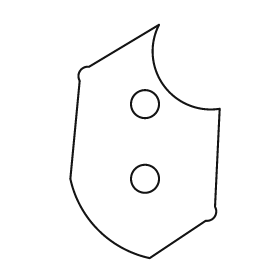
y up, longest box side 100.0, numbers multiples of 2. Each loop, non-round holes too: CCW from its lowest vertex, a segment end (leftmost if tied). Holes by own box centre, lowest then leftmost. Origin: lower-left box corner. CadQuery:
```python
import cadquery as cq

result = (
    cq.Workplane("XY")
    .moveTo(34.0, 0.0)
    .lineTo(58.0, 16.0)
    .threePointArc((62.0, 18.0), (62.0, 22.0))
    .lineTo(64.0, 64.0)
    .threePointArc((40.0, 74.0), (38.0, 100.0))
    .lineTo(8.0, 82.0)
    .threePointArc((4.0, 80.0), (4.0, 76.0))
    .lineTo(0.0, 34.0)
    .threePointArc((12.0, 12.0), (34.0, 0.0))
    .close()
    .moveTo(32.0, 34.0)
    .circle(6.0)
    .moveTo(32.0, 66.0)
    .circle(6.0)
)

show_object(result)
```